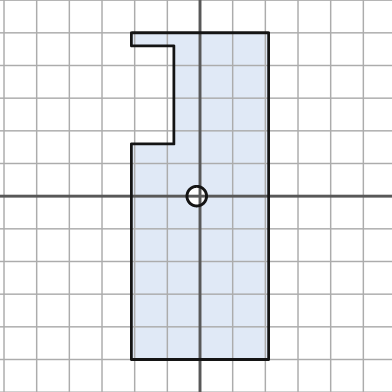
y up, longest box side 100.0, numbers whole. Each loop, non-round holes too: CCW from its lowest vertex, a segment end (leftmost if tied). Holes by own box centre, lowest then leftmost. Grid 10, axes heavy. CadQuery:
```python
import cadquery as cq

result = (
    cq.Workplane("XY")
    .moveTo(-21.0, -50.0)
    .lineTo(21.0, -50.0)
    .lineTo(21.0, 50.0)
    .lineTo(-21.0, 50.0)
    .lineTo(-21.0, 46.0)
    .lineTo(-8.0, 46.0)
    .lineTo(-8.0, 16.0)
    .lineTo(-21.0, 16.0)
    .close()
    .moveTo(-1.0, 0.0)
    .circle(3.0)
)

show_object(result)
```